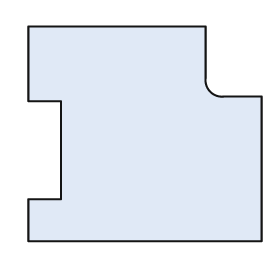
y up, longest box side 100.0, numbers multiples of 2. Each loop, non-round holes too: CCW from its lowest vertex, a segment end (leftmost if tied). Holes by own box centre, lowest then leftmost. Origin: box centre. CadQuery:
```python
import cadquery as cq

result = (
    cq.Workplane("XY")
    .moveTo(-50.0, -46.0)
    .lineTo(50.0, -46.0)
    .lineTo(50.0, 16.0)
    .lineTo(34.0, 16.0)
    .threePointArc((28.0, 18.0), (26.0, 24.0))
    .lineTo(26.0, 46.0)
    .lineTo(-50.0, 46.0)
    .lineTo(-50.0, 14.0)
    .lineTo(-36.0, 14.0)
    .lineTo(-36.0, -28.0)
    .lineTo(-50.0, -28.0)
    .close()
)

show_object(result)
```